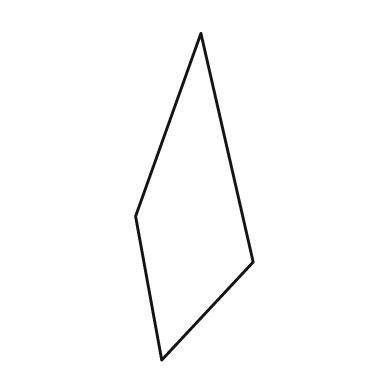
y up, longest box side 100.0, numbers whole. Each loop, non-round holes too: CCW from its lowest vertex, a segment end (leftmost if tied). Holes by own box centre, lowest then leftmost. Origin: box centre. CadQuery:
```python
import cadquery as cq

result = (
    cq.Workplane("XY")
    .moveTo(-10.0, -50.0)
    .lineTo(18.0, -20.0)
    .lineTo(2.0, 50.0)
    .lineTo(-18.0, -6.0)
    .close()
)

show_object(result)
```